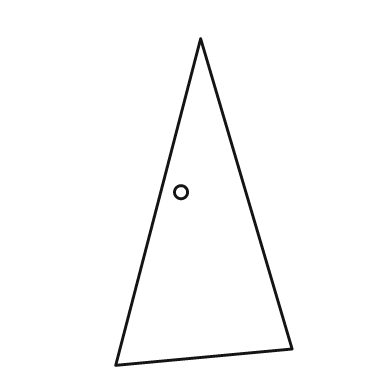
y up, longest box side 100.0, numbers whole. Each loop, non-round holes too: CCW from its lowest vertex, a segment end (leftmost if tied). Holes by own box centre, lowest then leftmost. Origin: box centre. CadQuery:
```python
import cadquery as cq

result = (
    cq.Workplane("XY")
    .moveTo(-27.0, -50.0)
    .lineTo(27.0, -45.0)
    .lineTo(-1.0, 50.0)
    .close()
    .moveTo(-7.0, 3.0)
    .circle(2.0)
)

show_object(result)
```